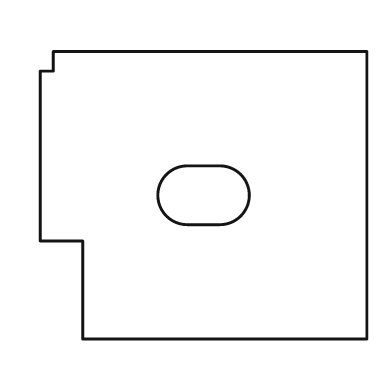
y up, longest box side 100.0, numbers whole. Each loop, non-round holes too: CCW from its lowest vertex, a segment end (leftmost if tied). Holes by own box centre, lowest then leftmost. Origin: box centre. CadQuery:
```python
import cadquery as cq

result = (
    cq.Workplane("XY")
    .moveTo(-37.0, -44.0)
    .lineTo(50.0, -44.0)
    .lineTo(50.0, 44.0)
    .lineTo(-46.0, 44.0)
    .lineTo(-46.0, 38.0)
    .lineTo(-50.0, 38.0)
    .lineTo(-50.0, -14.0)
    .lineTo(-37.0, -14.0)
    .close()
    .moveTo(-5.0, -9.0)
    .lineTo(5.0, -9.0)
    .threePointArc((14.0, 0.0), (5.0, 9.0))
    .lineTo(-5.0, 9.0)
    .threePointArc((-14.0, 0.0), (-5.0, -9.0))
    .close()
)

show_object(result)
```